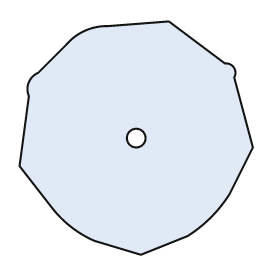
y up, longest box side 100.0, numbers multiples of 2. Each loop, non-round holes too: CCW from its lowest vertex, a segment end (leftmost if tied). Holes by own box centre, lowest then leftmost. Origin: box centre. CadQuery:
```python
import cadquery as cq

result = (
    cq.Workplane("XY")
    .moveTo(2.0, -50.0)
    .lineTo(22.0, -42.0)
    .threePointArc((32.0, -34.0), (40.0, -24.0))
    .lineTo(50.0, -4.0)
    .lineTo(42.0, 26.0)
    .threePointArc((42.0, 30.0), (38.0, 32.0))
    .lineTo(14.0, 50.0)
    .lineTo(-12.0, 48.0)
    .threePointArc((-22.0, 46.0), (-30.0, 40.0))
    .lineTo(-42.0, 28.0)
    .threePointArc((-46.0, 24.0), (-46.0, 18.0))
    .lineTo(-50.0, -12.0)
    .lineTo(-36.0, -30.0)
    .threePointArc((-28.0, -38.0), (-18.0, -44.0))
    .close()
    .moveTo(0.0, 0.0)
    .circle(4.0)
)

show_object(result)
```